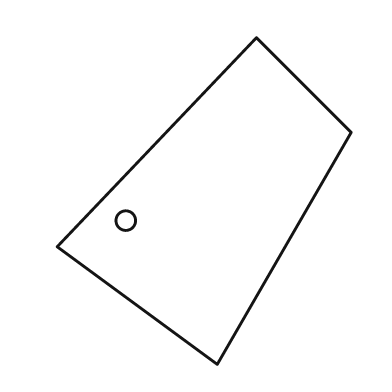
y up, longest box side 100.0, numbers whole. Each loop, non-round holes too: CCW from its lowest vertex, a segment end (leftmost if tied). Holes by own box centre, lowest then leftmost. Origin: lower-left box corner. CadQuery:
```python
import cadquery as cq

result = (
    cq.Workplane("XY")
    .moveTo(49.0, 0.0)
    .lineTo(90.0, 71.0)
    .lineTo(61.0, 100.0)
    .lineTo(0.0, 36.0)
    .close()
    .moveTo(21.0, 44.0)
    .circle(3.0)
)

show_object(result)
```